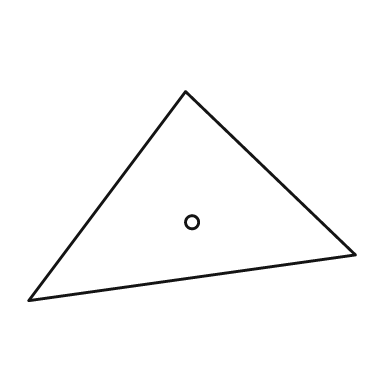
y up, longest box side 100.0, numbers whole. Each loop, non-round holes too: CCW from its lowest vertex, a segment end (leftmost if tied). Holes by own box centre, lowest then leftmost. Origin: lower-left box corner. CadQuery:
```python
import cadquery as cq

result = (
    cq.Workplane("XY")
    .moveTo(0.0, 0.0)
    .lineTo(100.0, 14.0)
    .lineTo(48.0, 64.0)
    .close()
    .moveTo(50.0, 24.0)
    .circle(2.0)
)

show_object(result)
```